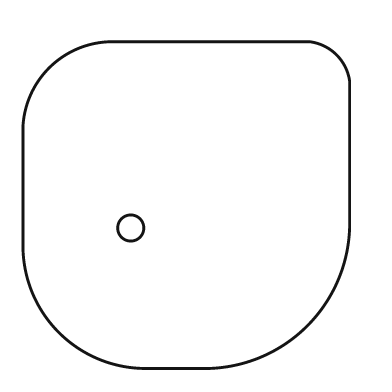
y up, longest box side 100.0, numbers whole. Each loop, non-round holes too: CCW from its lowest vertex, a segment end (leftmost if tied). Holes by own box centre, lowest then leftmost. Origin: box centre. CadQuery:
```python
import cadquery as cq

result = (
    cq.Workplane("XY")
    .moveTo(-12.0, -50.0)
    .lineTo(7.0, -50.0)
    .threePointArc((37.0, -37.0), (50.0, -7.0))
    .lineTo(50.0, 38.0)
    .threePointArc((46.0, 46.0), (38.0, 50.0))
    .lineTo(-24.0, 50.0)
    .threePointArc((-42.0, 42.0), (-50.0, 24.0))
    .lineTo(-50.0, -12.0)
    .threePointArc((-39.0, -39.0), (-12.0, -50.0))
    .close()
    .moveTo(-17.0, -7.0)
    .circle(4.0)
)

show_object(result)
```